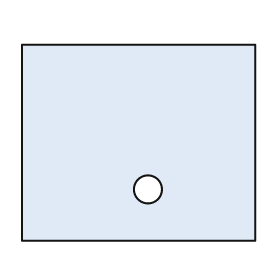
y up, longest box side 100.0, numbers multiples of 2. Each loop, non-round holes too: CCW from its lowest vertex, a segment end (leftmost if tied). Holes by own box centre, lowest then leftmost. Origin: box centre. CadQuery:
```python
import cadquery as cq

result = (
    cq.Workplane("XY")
    .moveTo(-50.0, -42.0)
    .lineTo(50.0, -42.0)
    .lineTo(50.0, 42.0)
    .lineTo(-50.0, 42.0)
    .close()
    .moveTo(4.0, -20.0)
    .circle(6.0)
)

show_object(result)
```